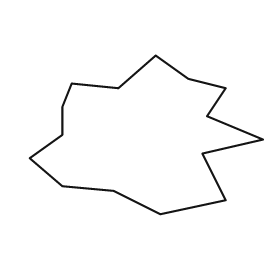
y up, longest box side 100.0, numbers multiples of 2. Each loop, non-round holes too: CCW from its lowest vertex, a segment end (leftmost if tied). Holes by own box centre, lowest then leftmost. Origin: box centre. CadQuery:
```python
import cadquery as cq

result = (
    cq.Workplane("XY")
    .moveTo(6.0, -34.0)
    .lineTo(34.0, -28.0)
    .lineTo(24.0, -8.0)
    .lineTo(50.0, -2.0)
    .lineTo(26.0, 8.0)
    .lineTo(34.0, 20.0)
    .lineTo(18.0, 24.0)
    .lineTo(4.0, 34.0)
    .lineTo(-12.0, 20.0)
    .lineTo(-32.0, 22.0)
    .lineTo(-36.0, 12.0)
    .lineTo(-36.0, 0.0)
    .lineTo(-50.0, -10.0)
    .lineTo(-36.0, -22.0)
    .lineTo(-14.0, -24.0)
    .close()
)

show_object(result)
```